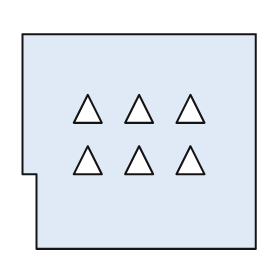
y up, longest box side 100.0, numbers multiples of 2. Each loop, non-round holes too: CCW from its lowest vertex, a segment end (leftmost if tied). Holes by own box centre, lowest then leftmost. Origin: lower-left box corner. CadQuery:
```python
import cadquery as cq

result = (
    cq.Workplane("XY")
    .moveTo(6.0, 0.0)
    .lineTo(100.0, 0.0)
    .lineTo(100.0, 92.0)
    .lineTo(0.0, 92.0)
    .lineTo(0.0, 32.0)
    .lineTo(6.0, 32.0)
    .close()
    .moveTo(22.0, 32.0)
    .lineTo(34.0, 32.0)
    .lineTo(28.0, 44.0)
    .close()
    .moveTo(44.0, 32.0)
    .lineTo(56.0, 32.0)
    .lineTo(50.0, 44.0)
    .close()
    .moveTo(66.0, 32.0)
    .lineTo(78.0, 32.0)
    .lineTo(72.0, 44.0)
    .close()
    .moveTo(22.0, 54.0)
    .lineTo(34.0, 54.0)
    .lineTo(28.0, 66.0)
    .close()
    .moveTo(44.0, 54.0)
    .lineTo(56.0, 54.0)
    .lineTo(50.0, 66.0)
    .close()
    .moveTo(66.0, 54.0)
    .lineTo(78.0, 54.0)
    .lineTo(72.0, 66.0)
    .close()
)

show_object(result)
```